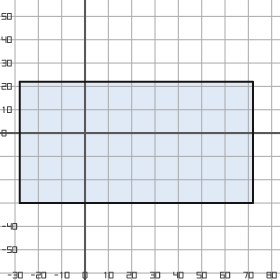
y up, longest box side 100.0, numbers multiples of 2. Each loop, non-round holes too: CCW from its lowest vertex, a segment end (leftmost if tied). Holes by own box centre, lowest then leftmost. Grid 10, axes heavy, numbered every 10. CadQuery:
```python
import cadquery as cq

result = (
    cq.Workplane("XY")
    .moveTo(-28.0, -30.0)
    .lineTo(72.0, -30.0)
    .lineTo(72.0, 22.0)
    .lineTo(-28.0, 22.0)
    .close()
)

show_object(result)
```